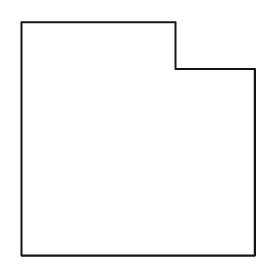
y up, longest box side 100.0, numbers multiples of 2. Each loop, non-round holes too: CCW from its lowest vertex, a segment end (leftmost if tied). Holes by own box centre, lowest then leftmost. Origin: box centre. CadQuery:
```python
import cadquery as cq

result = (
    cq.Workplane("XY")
    .moveTo(-50.0, -50.0)
    .lineTo(50.0, -50.0)
    .lineTo(50.0, 30.0)
    .lineTo(16.0, 30.0)
    .lineTo(16.0, 50.0)
    .lineTo(-50.0, 50.0)
    .close()
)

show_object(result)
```